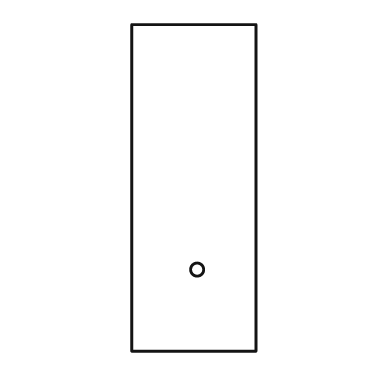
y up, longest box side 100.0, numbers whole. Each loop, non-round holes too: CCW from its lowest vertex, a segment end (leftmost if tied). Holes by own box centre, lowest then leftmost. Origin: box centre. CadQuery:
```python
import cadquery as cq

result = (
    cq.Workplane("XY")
    .moveTo(-19.0, -50.0)
    .lineTo(19.0, -50.0)
    .lineTo(19.0, 50.0)
    .lineTo(-19.0, 50.0)
    .close()
    .moveTo(1.0, -25.0)
    .circle(2.0)
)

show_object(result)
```